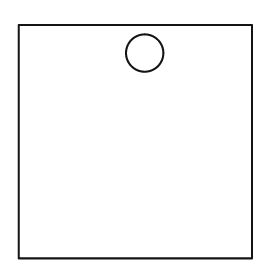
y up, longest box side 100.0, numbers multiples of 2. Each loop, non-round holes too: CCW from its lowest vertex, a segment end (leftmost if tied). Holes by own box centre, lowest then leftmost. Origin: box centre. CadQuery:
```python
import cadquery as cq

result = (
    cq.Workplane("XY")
    .moveTo(-50.0, -50.0)
    .lineTo(50.0, -50.0)
    .lineTo(50.0, 50.0)
    .lineTo(-50.0, 50.0)
    .close()
    .moveTo(4.0, 38.0)
    .circle(8.0)
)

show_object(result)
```